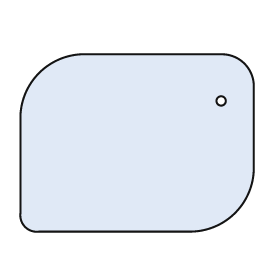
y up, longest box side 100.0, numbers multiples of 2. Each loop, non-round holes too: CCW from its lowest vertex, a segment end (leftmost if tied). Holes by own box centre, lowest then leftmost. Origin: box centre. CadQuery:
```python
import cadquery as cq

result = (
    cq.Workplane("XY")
    .moveTo(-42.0, -38.0)
    .lineTo(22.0, -38.0)
    .threePointArc((42.0, -30.0), (50.0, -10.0))
    .lineTo(50.0, 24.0)
    .threePointArc((46.0, 34.0), (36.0, 38.0))
    .lineTo(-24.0, 38.0)
    .threePointArc((-42.0, 30.0), (-50.0, 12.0))
    .lineTo(-50.0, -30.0)
    .threePointArc((-48.0, -36.0), (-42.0, -38.0))
    .close()
    .moveTo(36.0, 18.0)
    .circle(2.0)
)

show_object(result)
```